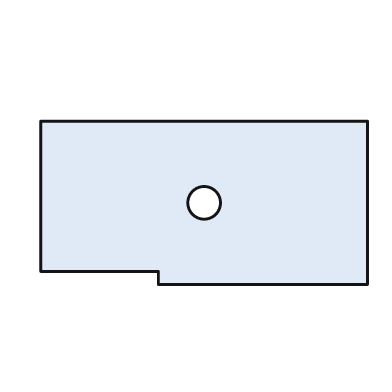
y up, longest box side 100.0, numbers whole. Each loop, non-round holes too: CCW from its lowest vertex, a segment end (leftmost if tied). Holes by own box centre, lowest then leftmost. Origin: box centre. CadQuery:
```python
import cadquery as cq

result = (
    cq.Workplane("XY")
    .moveTo(-14.0, -25.0)
    .lineTo(50.0, -25.0)
    .lineTo(50.0, 25.0)
    .lineTo(-50.0, 25.0)
    .lineTo(-50.0, -21.0)
    .lineTo(-14.0, -21.0)
    .close()
    .moveTo(0.0, 0.0)
    .circle(5.0)
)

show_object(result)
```